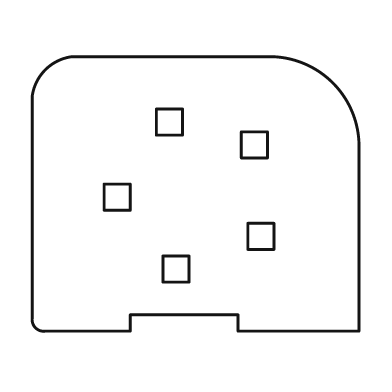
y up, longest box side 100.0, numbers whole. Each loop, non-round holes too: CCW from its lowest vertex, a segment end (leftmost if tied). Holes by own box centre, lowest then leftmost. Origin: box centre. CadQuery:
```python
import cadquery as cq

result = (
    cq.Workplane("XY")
    .moveTo(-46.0, -42.0)
    .lineTo(-20.0, -42.0)
    .lineTo(-20.0, -37.0)
    .lineTo(13.0, -37.0)
    .lineTo(13.0, -42.0)
    .lineTo(50.0, -42.0)
    .lineTo(50.0, 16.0)
    .threePointArc((42.0, 34.0), (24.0, 42.0))
    .lineTo(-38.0, 42.0)
    .threePointArc((-46.0, 38.0), (-50.0, 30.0))
    .lineTo(-50.0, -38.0)
    .threePointArc((-49.0, -41.0), (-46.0, -42.0))
    .close()
    .moveTo(-10.0, -27.0)
    .lineTo(-2.0, -27.0)
    .lineTo(-2.0, -19.0)
    .lineTo(-10.0, -19.0)
    .close()
    .moveTo(16.0, -17.0)
    .lineTo(24.0, -17.0)
    .lineTo(24.0, -9.0)
    .lineTo(16.0, -9.0)
    .close()
    .moveTo(-28.0, -5.0)
    .lineTo(-20.0, -5.0)
    .lineTo(-20.0, 3.0)
    .lineTo(-28.0, 3.0)
    .close()
    .moveTo(14.0, 11.0)
    .lineTo(22.0, 11.0)
    .lineTo(22.0, 19.0)
    .lineTo(14.0, 19.0)
    .close()
    .moveTo(-12.0, 18.0)
    .lineTo(-4.0, 18.0)
    .lineTo(-4.0, 26.0)
    .lineTo(-12.0, 26.0)
    .close()
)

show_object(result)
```